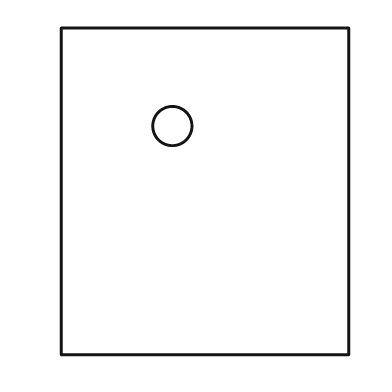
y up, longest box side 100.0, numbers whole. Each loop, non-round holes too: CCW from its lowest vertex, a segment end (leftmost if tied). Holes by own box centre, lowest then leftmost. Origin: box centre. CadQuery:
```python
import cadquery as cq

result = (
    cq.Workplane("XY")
    .moveTo(-44.0, -50.0)
    .lineTo(44.0, -50.0)
    .lineTo(44.0, 50.0)
    .lineTo(-44.0, 50.0)
    .close()
    .moveTo(-10.0, 20.0)
    .circle(6.0)
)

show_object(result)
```